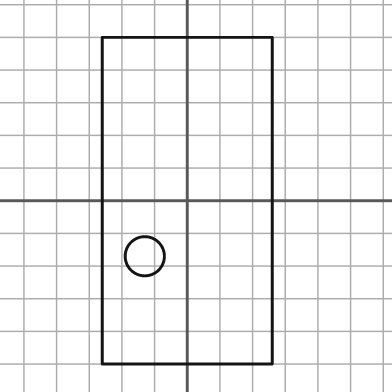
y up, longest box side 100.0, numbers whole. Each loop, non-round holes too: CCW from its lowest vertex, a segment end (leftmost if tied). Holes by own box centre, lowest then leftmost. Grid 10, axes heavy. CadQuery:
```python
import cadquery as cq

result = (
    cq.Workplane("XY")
    .moveTo(-26.0, -50.0)
    .lineTo(26.0, -50.0)
    .lineTo(26.0, 50.0)
    .lineTo(-26.0, 50.0)
    .close()
    .moveTo(-13.0, -17.0)
    .circle(6.0)
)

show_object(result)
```